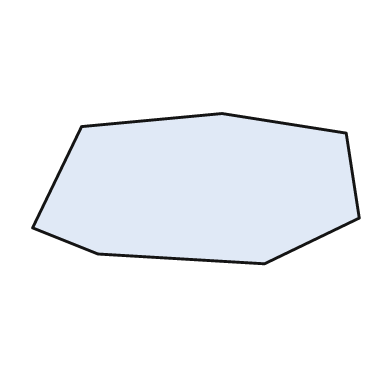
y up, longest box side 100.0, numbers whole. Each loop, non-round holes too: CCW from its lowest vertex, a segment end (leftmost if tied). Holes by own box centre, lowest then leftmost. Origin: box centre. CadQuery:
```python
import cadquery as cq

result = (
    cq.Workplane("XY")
    .moveTo(21.0, -23.0)
    .lineTo(50.0, -9.0)
    .lineTo(46.0, 17.0)
    .lineTo(8.0, 23.0)
    .lineTo(-35.0, 19.0)
    .lineTo(-50.0, -12.0)
    .lineTo(-30.0, -20.0)
    .close()
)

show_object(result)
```